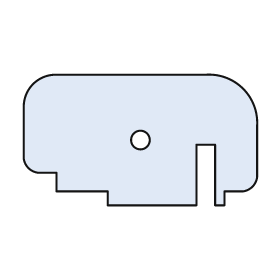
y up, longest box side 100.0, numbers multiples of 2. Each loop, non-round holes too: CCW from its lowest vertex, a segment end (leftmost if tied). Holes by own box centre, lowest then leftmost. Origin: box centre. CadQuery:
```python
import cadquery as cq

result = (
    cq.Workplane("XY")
    .moveTo(-14.0, -28.0)
    .lineTo(24.0, -28.0)
    .lineTo(24.0, -2.0)
    .lineTo(32.0, -2.0)
    .lineTo(32.0, -28.0)
    .lineTo(36.0, -28.0)
    .lineTo(36.0, -22.0)
    .lineTo(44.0, -22.0)
    .threePointArc((48.0, -20.0), (50.0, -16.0))
    .lineTo(50.0, 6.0)
    .threePointArc((44.0, 22.0), (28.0, 28.0))
    .lineTo(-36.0, 28.0)
    .threePointArc((-46.0, 24.0), (-50.0, 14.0))
    .lineTo(-50.0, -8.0)
    .threePointArc((-48.0, -12.0), (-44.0, -14.0))
    .lineTo(-36.0, -14.0)
    .lineTo(-36.0, -22.0)
    .lineTo(-14.0, -22.0)
    .close()
    .moveTo(0.0, 0.0)
    .circle(4.0)
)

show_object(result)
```